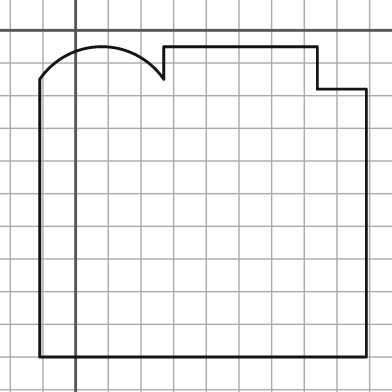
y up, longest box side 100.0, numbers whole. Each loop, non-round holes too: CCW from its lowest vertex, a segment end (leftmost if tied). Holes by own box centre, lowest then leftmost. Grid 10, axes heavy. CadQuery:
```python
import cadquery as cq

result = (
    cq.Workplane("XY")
    .moveTo(-11.0, -100.0)
    .lineTo(89.0, -100.0)
    .lineTo(89.0, -18.0)
    .lineTo(74.0, -18.0)
    .lineTo(74.0, -5.0)
    .lineTo(27.0, -5.0)
    .lineTo(27.0, -15.0)
    .threePointArc((8.0, -5.0), (-11.0, -15.0))
    .close()
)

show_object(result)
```